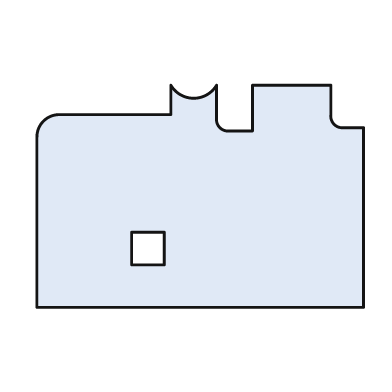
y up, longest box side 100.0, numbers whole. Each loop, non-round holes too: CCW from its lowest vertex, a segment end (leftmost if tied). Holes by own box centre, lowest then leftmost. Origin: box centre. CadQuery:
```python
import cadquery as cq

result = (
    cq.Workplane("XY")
    .moveTo(-50.0, -34.0)
    .lineTo(50.0, -34.0)
    .lineTo(50.0, 21.0)
    .lineTo(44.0, 21.0)
    .threePointArc((41.0, 22.0), (40.0, 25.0))
    .lineTo(40.0, 34.0)
    .lineTo(16.0, 34.0)
    .lineTo(16.0, 20.0)
    .lineTo(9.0, 20.0)
    .threePointArc((6.0, 21.0), (5.0, 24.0))
    .lineTo(5.0, 34.0)
    .threePointArc((-2.0, 30.0), (-9.0, 34.0))
    .lineTo(-9.0, 25.0)
    .lineTo(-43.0, 25.0)
    .threePointArc((-48.0, 23.0), (-50.0, 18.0))
    .close()
    .moveTo(-21.0, -21.0)
    .lineTo(-11.0, -21.0)
    .lineTo(-11.0, -11.0)
    .lineTo(-21.0, -11.0)
    .close()
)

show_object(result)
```